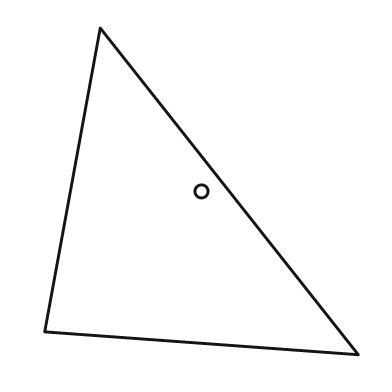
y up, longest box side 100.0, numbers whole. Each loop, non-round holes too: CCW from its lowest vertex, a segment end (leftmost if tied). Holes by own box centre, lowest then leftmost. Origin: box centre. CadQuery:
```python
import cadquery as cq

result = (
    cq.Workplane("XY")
    .moveTo(48.0, -50.0)
    .lineTo(-31.0, 50.0)
    .lineTo(-48.0, -43.0)
    .close()
    .moveTo(0.0, 0.0)
    .circle(2.0)
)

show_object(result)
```